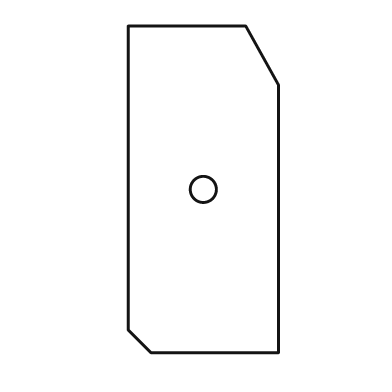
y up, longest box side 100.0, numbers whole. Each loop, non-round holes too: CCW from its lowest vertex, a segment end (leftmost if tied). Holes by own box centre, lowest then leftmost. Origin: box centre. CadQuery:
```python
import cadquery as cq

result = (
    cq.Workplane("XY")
    .moveTo(-16.0, -50.0)
    .lineTo(23.0, -50.0)
    .lineTo(23.0, 32.0)
    .lineTo(13.0, 50.0)
    .lineTo(-23.0, 50.0)
    .lineTo(-23.0, -43.0)
    .close()
    .moveTo(0.0, 0.0)
    .circle(4.0)
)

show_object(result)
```